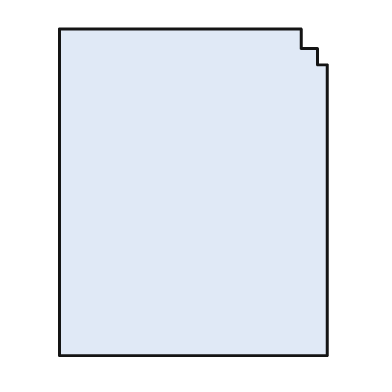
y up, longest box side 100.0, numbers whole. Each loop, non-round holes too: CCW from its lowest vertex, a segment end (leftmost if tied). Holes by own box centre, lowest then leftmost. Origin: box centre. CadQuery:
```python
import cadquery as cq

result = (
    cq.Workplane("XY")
    .moveTo(-41.0, -50.0)
    .lineTo(41.0, -50.0)
    .lineTo(41.0, 39.0)
    .lineTo(38.0, 39.0)
    .lineTo(38.0, 44.0)
    .lineTo(33.0, 44.0)
    .lineTo(33.0, 50.0)
    .lineTo(-41.0, 50.0)
    .close()
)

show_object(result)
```